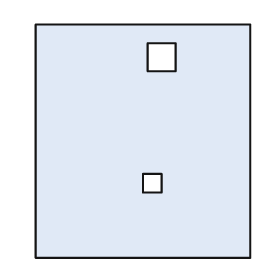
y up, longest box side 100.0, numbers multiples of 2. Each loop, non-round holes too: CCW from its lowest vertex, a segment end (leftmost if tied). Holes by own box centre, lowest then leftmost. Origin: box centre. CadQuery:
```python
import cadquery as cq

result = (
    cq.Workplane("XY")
    .moveTo(-46.0, -50.0)
    .lineTo(46.0, -50.0)
    .lineTo(46.0, 50.0)
    .lineTo(-46.0, 50.0)
    .close()
    .moveTo(0.0, -22.0)
    .lineTo(8.0, -22.0)
    .lineTo(8.0, -14.0)
    .lineTo(0.0, -14.0)
    .close()
    .moveTo(2.0, 30.0)
    .lineTo(14.0, 30.0)
    .lineTo(14.0, 42.0)
    .lineTo(2.0, 42.0)
    .close()
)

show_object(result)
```